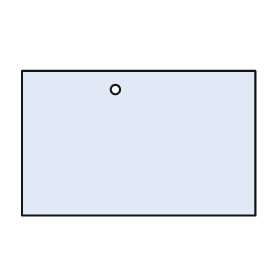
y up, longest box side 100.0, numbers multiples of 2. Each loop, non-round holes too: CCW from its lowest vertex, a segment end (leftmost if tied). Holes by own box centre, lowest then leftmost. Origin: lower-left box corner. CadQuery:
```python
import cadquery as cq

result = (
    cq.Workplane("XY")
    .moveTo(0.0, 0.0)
    .lineTo(100.0, 0.0)
    .lineTo(100.0, 62.0)
    .lineTo(0.0, 62.0)
    .close()
    .moveTo(40.0, 54.0)
    .circle(2.0)
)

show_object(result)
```